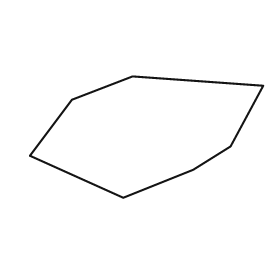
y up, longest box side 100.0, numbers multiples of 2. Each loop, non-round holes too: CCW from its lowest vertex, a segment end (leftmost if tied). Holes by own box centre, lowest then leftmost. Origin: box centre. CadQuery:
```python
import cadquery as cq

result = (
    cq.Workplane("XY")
    .moveTo(-10.0, -26.0)
    .lineTo(20.0, -14.0)
    .lineTo(36.0, -4.0)
    .lineTo(50.0, 22.0)
    .lineTo(-6.0, 26.0)
    .lineTo(-32.0, 16.0)
    .lineTo(-50.0, -8.0)
    .close()
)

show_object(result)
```